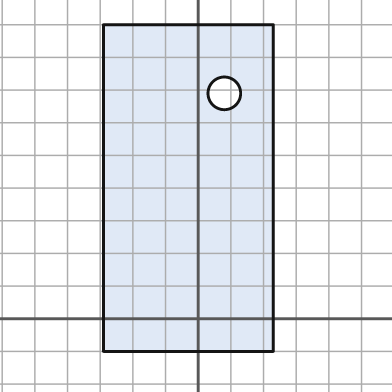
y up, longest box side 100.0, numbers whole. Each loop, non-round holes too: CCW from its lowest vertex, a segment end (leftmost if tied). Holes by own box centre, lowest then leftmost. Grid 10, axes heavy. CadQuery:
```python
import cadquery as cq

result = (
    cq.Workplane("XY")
    .moveTo(-29.0, -10.0)
    .lineTo(23.0, -10.0)
    .lineTo(23.0, 90.0)
    .lineTo(-29.0, 90.0)
    .close()
    .moveTo(8.0, 69.0)
    .circle(5.0)
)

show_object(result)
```